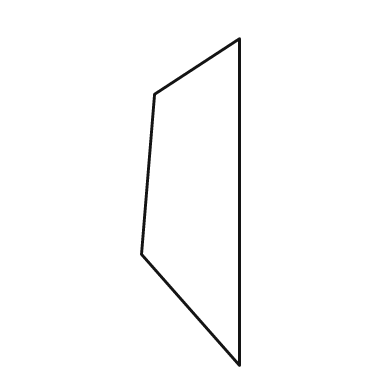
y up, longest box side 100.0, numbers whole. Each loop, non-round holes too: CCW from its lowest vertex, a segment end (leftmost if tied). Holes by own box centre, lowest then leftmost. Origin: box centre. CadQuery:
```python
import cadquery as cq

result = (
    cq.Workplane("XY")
    .moveTo(15.0, -50.0)
    .lineTo(15.0, 50.0)
    .lineTo(-11.0, 33.0)
    .lineTo(-15.0, -16.0)
    .close()
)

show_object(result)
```